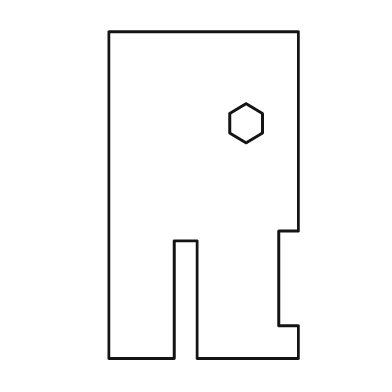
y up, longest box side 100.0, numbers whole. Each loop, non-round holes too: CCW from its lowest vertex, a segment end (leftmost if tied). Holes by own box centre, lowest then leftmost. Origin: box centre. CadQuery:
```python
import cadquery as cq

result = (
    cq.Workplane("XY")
    .moveTo(-29.0, -50.0)
    .lineTo(-9.0, -50.0)
    .lineTo(-9.0, -14.0)
    .lineTo(-2.0, -14.0)
    .lineTo(-2.0, -50.0)
    .lineTo(29.0, -50.0)
    .lineTo(29.0, -40.0)
    .lineTo(23.0, -40.0)
    .lineTo(23.0, -11.0)
    .lineTo(29.0, -11.0)
    .lineTo(29.0, 50.0)
    .lineTo(-29.0, 50.0)
    .close()
    .moveTo(13.0, 16.0)
    .lineTo(18.0, 19.0)
    .lineTo(18.0, 25.0)
    .lineTo(13.0, 28.0)
    .lineTo(8.0, 25.0)
    .lineTo(8.0, 19.0)
    .close()
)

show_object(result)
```